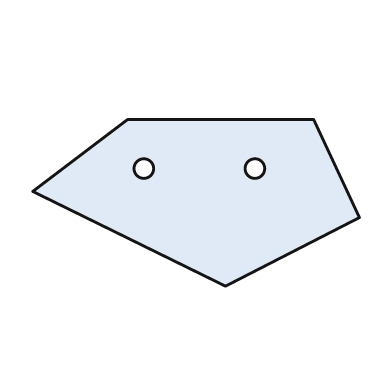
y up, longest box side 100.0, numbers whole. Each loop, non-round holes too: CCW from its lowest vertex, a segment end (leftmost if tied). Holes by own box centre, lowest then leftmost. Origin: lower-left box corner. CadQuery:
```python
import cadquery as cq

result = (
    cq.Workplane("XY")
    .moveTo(59.0, 0.0)
    .lineTo(100.0, 21.0)
    .lineTo(86.0, 51.0)
    .lineTo(29.0, 51.0)
    .lineTo(0.0, 29.0)
    .close()
    .moveTo(34.0, 36.0)
    .circle(3.0)
    .moveTo(68.0, 36.0)
    .circle(3.0)
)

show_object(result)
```